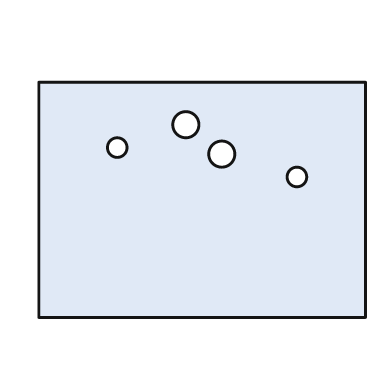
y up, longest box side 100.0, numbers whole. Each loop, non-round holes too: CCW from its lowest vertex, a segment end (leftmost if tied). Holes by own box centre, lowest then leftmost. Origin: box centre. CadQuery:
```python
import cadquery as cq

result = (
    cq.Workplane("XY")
    .moveTo(-50.0, -36.0)
    .lineTo(50.0, -36.0)
    .lineTo(50.0, 36.0)
    .lineTo(-50.0, 36.0)
    .close()
    .moveTo(29.0, 7.0)
    .circle(3.0)
    .moveTo(6.0, 14.0)
    .circle(4.0)
    .moveTo(-26.0, 16.0)
    .circle(3.0)
    .moveTo(-5.0, 23.0)
    .circle(4.0)
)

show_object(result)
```